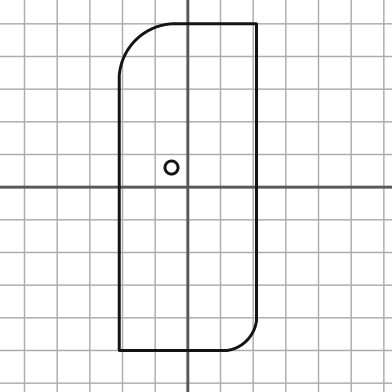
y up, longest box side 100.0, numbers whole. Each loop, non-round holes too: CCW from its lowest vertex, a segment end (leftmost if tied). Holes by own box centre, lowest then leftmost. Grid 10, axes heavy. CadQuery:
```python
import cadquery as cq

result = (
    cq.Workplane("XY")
    .moveTo(-21.0, -50.0)
    .lineTo(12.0, -50.0)
    .threePointArc((18.0, -47.0), (21.0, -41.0))
    .lineTo(21.0, 50.0)
    .lineTo(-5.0, 50.0)
    .threePointArc((-16.0, 45.0), (-21.0, 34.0))
    .close()
    .moveTo(-5.0, 6.0)
    .circle(2.0)
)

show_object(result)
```